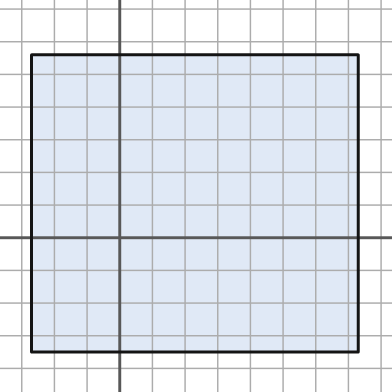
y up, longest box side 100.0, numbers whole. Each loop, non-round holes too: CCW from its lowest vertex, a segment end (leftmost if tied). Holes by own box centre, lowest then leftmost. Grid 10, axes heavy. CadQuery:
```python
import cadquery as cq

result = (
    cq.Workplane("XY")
    .moveTo(-27.0, -35.0)
    .lineTo(73.0, -35.0)
    .lineTo(73.0, 56.0)
    .lineTo(-27.0, 56.0)
    .close()
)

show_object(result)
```